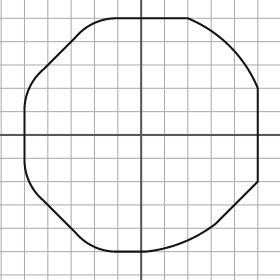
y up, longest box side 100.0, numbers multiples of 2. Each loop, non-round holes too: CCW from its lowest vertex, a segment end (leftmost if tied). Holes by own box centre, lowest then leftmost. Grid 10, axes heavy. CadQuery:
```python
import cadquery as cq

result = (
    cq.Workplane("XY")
    .moveTo(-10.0, -50.0)
    .lineTo(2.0, -50.0)
    .threePointArc((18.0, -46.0), (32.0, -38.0))
    .lineTo(50.0, -20.0)
    .lineTo(50.0, 20.0)
    .threePointArc((38.0, 38.0), (20.0, 50.0))
    .lineTo(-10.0, 50.0)
    .threePointArc((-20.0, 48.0), (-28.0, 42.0))
    .lineTo(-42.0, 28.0)
    .threePointArc((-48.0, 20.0), (-50.0, 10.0))
    .lineTo(-50.0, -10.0)
    .threePointArc((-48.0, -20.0), (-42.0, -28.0))
    .lineTo(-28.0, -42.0)
    .threePointArc((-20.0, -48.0), (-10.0, -50.0))
    .close()
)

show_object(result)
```